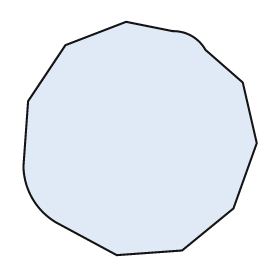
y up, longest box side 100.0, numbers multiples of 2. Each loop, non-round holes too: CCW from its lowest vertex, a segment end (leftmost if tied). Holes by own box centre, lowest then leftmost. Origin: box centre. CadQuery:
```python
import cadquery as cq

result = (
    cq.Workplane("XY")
    .moveTo(-10.0, -50.0)
    .lineTo(18.0, -48.0)
    .lineTo(40.0, -30.0)
    .lineTo(50.0, -2.0)
    .lineTo(44.0, 24.0)
    .lineTo(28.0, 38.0)
    .threePointArc((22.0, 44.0), (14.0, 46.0))
    .lineTo(-6.0, 50.0)
    .lineTo(-32.0, 40.0)
    .lineTo(-48.0, 16.0)
    .lineTo(-50.0, -12.0)
    .threePointArc((-46.0, -26.0), (-36.0, -36.0))
    .close()
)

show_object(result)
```